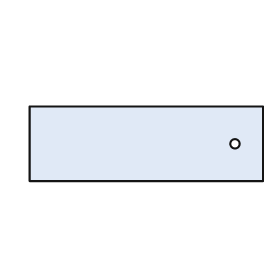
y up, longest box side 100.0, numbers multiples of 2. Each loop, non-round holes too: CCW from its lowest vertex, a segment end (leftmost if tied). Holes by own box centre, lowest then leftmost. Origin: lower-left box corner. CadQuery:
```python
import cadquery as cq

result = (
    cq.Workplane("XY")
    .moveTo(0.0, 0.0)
    .lineTo(100.0, 0.0)
    .lineTo(100.0, 32.0)
    .lineTo(0.0, 32.0)
    .close()
    .moveTo(88.0, 16.0)
    .circle(2.0)
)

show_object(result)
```